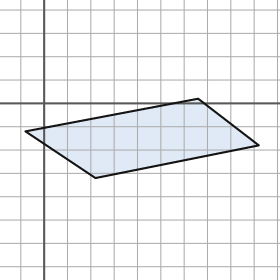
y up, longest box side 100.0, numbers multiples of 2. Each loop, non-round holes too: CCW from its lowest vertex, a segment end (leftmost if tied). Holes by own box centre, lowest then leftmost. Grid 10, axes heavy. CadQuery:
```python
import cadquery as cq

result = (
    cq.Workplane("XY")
    .moveTo(22.0, -32.0)
    .lineTo(92.0, -18.0)
    .lineTo(66.0, 2.0)
    .lineTo(-8.0, -12.0)
    .close()
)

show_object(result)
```